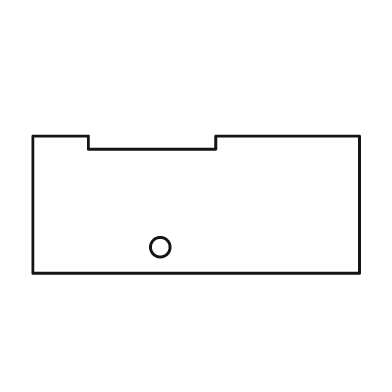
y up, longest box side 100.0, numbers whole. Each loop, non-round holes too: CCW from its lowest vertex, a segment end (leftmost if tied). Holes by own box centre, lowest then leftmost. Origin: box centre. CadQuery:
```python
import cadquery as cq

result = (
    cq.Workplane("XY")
    .moveTo(-50.0, -21.0)
    .lineTo(50.0, -21.0)
    .lineTo(50.0, 21.0)
    .lineTo(6.0, 21.0)
    .lineTo(6.0, 17.0)
    .lineTo(-33.0, 17.0)
    .lineTo(-33.0, 21.0)
    .lineTo(-50.0, 21.0)
    .close()
    .moveTo(-11.0, -13.0)
    .circle(3.0)
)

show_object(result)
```